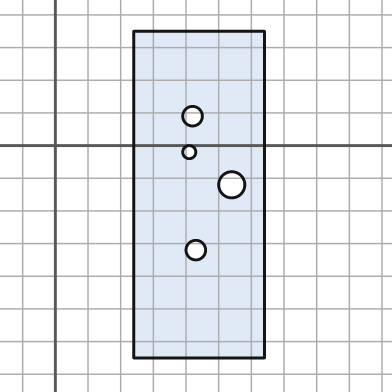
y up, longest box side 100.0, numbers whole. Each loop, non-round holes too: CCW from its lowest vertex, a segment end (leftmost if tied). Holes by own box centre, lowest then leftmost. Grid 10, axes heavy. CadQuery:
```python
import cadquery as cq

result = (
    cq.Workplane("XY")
    .moveTo(24.0, -65.0)
    .lineTo(64.0, -65.0)
    .lineTo(64.0, 35.0)
    .lineTo(24.0, 35.0)
    .close()
    .moveTo(43.0, -32.0)
    .circle(3.0)
    .moveTo(54.0, -12.0)
    .circle(4.0)
    .moveTo(41.0, -2.0)
    .circle(2.0)
    .moveTo(42.0, 9.0)
    .circle(3.0)
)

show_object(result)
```